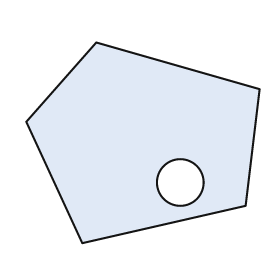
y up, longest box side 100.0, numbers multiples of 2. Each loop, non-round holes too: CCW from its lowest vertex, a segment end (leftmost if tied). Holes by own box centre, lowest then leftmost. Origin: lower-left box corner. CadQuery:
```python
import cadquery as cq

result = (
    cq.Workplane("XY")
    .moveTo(24.0, 0.0)
    .lineTo(94.0, 16.0)
    .lineTo(100.0, 66.0)
    .lineTo(30.0, 86.0)
    .lineTo(0.0, 52.0)
    .close()
    .moveTo(66.0, 26.0)
    .circle(10.0)
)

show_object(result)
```